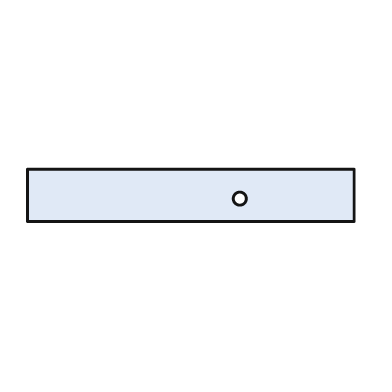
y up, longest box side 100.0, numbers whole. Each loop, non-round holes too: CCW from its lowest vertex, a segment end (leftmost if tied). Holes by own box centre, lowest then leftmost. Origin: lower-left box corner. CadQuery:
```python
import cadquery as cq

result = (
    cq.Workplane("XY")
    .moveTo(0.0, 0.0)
    .lineTo(100.0, 0.0)
    .lineTo(100.0, 16.0)
    .lineTo(0.0, 16.0)
    .close()
    .moveTo(65.0, 7.0)
    .circle(2.0)
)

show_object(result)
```